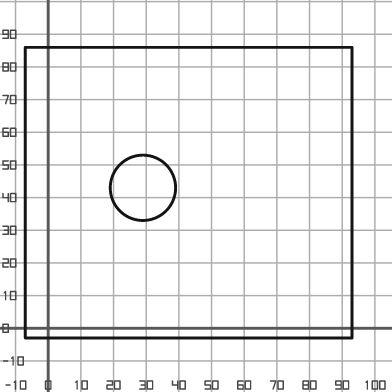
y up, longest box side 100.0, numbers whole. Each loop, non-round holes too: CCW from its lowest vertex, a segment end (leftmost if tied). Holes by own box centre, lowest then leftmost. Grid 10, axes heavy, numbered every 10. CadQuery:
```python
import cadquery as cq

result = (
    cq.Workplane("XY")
    .moveTo(-7.0, -3.0)
    .lineTo(93.0, -3.0)
    .lineTo(93.0, 86.0)
    .lineTo(-7.0, 86.0)
    .close()
    .moveTo(29.0, 43.0)
    .circle(10.0)
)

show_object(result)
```